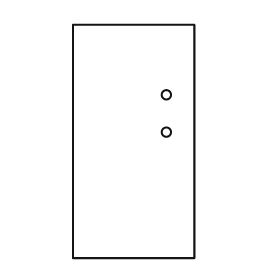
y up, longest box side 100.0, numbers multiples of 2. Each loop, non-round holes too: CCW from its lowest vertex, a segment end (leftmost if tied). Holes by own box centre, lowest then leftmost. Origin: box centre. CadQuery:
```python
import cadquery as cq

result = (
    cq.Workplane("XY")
    .moveTo(-26.0, -50.0)
    .lineTo(26.0, -50.0)
    .lineTo(26.0, 50.0)
    .lineTo(-26.0, 50.0)
    .close()
    .moveTo(14.0, 4.0)
    .circle(2.0)
    .moveTo(14.0, 20.0)
    .circle(2.0)
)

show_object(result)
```